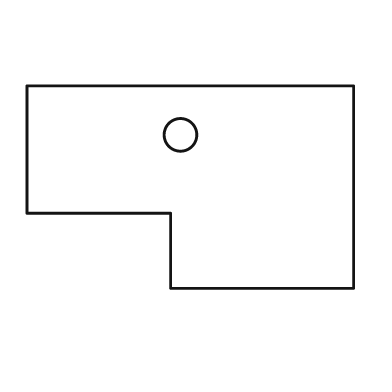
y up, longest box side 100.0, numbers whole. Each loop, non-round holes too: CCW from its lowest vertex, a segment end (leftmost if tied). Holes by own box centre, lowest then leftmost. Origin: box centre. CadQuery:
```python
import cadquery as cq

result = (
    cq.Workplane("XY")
    .moveTo(-6.0, -31.0)
    .lineTo(50.0, -31.0)
    .lineTo(50.0, 31.0)
    .lineTo(-50.0, 31.0)
    .lineTo(-50.0, -8.0)
    .lineTo(-6.0, -8.0)
    .close()
    .moveTo(-3.0, 16.0)
    .circle(5.0)
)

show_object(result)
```